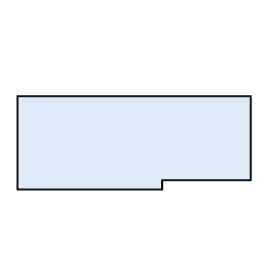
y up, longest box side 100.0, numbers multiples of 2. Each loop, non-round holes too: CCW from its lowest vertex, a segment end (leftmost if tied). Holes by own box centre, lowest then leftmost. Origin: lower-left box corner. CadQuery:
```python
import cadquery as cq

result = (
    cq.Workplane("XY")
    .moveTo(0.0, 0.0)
    .lineTo(62.0, 0.0)
    .lineTo(62.0, 4.0)
    .lineTo(100.0, 4.0)
    .lineTo(100.0, 40.0)
    .lineTo(0.0, 40.0)
    .close()
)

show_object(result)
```